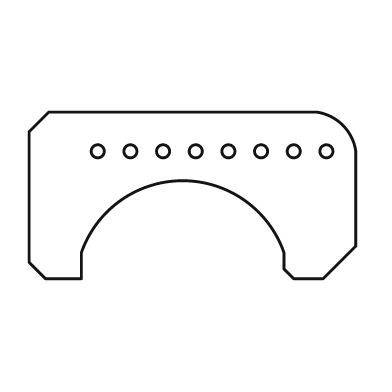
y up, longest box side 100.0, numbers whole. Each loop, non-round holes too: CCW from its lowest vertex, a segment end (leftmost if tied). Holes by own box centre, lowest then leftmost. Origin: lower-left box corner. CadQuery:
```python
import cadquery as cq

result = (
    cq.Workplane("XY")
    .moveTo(5.0, 0.0)
    .lineTo(16.0, 0.0)
    .lineTo(16.0, 8.0)
    .threePointArc((47.0, 30.0), (78.0, 8.0))
    .lineTo(78.0, 3.0)
    .lineTo(81.0, 0.0)
    .lineTo(90.0, 0.0)
    .lineTo(100.0, 10.0)
    .lineTo(100.0, 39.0)
    .threePointArc((96.0, 47.0), (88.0, 51.0))
    .lineTo(6.0, 51.0)
    .lineTo(0.0, 45.0)
    .lineTo(0.0, 5.0)
    .close()
    .moveTo(21.0, 39.0)
    .circle(2.0)
    .moveTo(31.0, 39.0)
    .circle(2.0)
    .moveTo(41.0, 39.0)
    .circle(2.0)
    .moveTo(51.0, 39.0)
    .circle(2.0)
    .moveTo(61.0, 39.0)
    .circle(2.0)
    .moveTo(71.0, 39.0)
    .circle(2.0)
    .moveTo(81.0, 39.0)
    .circle(2.0)
    .moveTo(91.0, 39.0)
    .circle(2.0)
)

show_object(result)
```